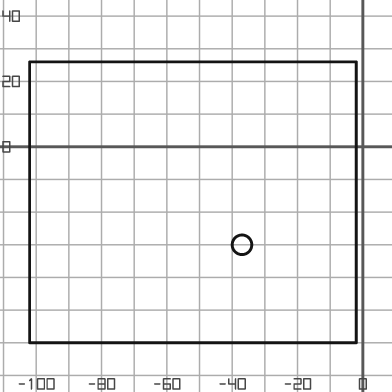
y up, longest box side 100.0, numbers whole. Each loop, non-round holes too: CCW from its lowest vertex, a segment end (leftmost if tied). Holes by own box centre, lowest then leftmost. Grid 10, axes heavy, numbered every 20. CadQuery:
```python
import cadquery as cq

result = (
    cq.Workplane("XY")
    .moveTo(-102.0, -60.0)
    .lineTo(-2.0, -60.0)
    .lineTo(-2.0, 26.0)
    .lineTo(-102.0, 26.0)
    .close()
    .moveTo(-37.0, -30.0)
    .circle(3.0)
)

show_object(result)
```